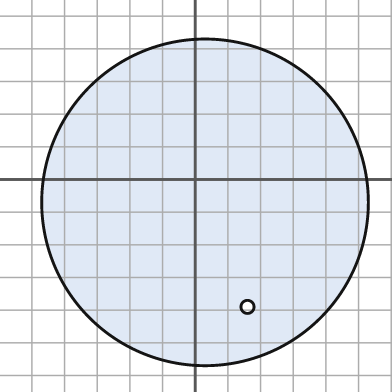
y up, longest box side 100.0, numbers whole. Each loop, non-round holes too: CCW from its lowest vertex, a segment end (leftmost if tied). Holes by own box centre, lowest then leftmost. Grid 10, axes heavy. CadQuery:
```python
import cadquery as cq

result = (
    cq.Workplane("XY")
    .moveTo(3.0, -7.0)
    .circle(50.0)
    .moveTo(16.0, -39.0)
    .circle(2.0)
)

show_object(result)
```